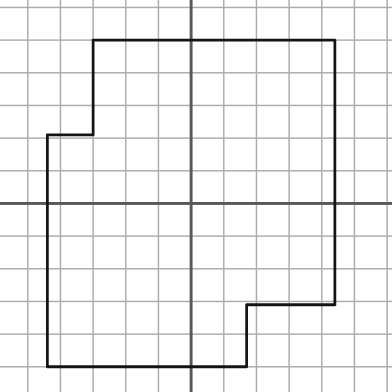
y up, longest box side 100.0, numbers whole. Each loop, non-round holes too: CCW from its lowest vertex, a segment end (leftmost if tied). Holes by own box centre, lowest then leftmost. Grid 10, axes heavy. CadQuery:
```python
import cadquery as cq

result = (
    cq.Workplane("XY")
    .moveTo(-44.0, -50.0)
    .lineTo(17.0, -50.0)
    .lineTo(17.0, -31.0)
    .lineTo(44.0, -31.0)
    .lineTo(44.0, 50.0)
    .lineTo(-30.0, 50.0)
    .lineTo(-30.0, 21.0)
    .lineTo(-44.0, 21.0)
    .close()
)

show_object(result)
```